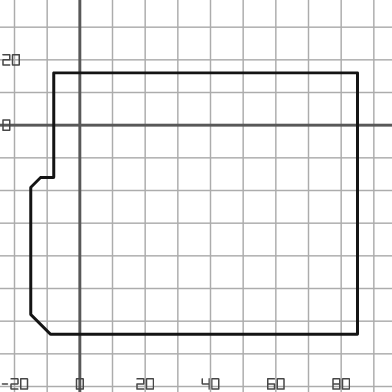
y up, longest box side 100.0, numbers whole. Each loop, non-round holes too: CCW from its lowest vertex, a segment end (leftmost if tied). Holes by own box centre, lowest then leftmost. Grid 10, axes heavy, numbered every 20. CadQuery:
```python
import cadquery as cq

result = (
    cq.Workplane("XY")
    .moveTo(-9.0, -64.0)
    .lineTo(85.0, -64.0)
    .lineTo(85.0, 16.0)
    .lineTo(-8.0, 16.0)
    .lineTo(-8.0, -16.0)
    .lineTo(-12.0, -16.0)
    .lineTo(-15.0, -19.0)
    .lineTo(-15.0, -58.0)
    .close()
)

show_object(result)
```